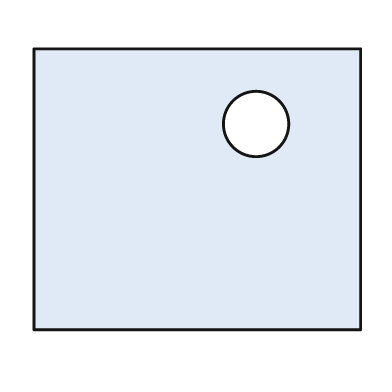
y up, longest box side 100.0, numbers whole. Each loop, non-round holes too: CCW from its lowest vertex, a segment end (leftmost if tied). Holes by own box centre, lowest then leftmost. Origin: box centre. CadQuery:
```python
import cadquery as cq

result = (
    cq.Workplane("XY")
    .moveTo(-50.0, -43.0)
    .lineTo(50.0, -43.0)
    .lineTo(50.0, 43.0)
    .lineTo(-50.0, 43.0)
    .close()
    .moveTo(18.0, 20.0)
    .circle(10.0)
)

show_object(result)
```